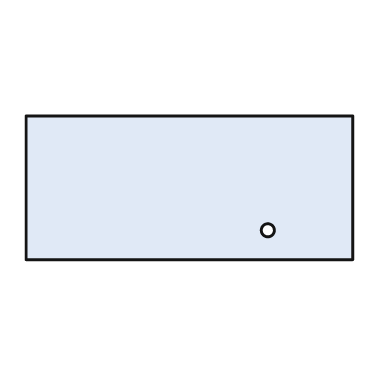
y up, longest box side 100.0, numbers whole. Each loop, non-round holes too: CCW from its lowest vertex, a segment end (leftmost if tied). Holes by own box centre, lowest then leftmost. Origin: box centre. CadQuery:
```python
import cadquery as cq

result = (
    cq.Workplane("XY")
    .moveTo(-50.0, -22.0)
    .lineTo(50.0, -22.0)
    .lineTo(50.0, 22.0)
    .lineTo(-50.0, 22.0)
    .close()
    .moveTo(24.0, -13.0)
    .circle(2.0)
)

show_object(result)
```